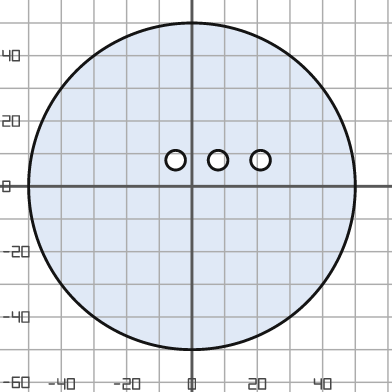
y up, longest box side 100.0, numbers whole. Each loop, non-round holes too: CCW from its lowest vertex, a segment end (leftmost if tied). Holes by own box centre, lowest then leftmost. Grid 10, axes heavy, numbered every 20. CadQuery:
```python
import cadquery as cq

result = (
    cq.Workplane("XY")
    .moveTo(0.0, 0.0)
    .circle(50.0)
    .moveTo(-5.0, 8.0)
    .circle(3.0)
    .moveTo(8.0, 8.0)
    .circle(3.0)
    .moveTo(21.0, 8.0)
    .circle(3.0)
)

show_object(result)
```